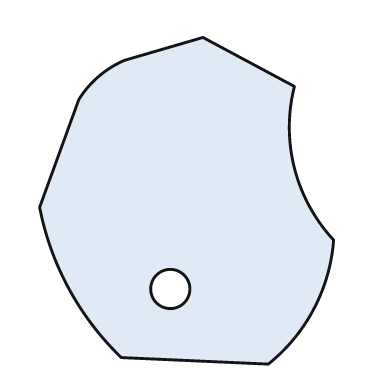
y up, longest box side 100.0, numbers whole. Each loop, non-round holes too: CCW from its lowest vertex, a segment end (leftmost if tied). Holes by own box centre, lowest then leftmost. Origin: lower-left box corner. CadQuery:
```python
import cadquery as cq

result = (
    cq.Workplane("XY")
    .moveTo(70.0, 0.0)
    .threePointArc((84.0, 17.0), (90.0, 38.0))
    .threePointArc((78.0, 60.0), (78.0, 85.0))
    .lineTo(50.0, 100.0)
    .lineTo(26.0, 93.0)
    .threePointArc((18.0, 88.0), (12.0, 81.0))
    .lineTo(0.0, 48.0)
    .threePointArc((9.0, 23.0), (25.0, 2.0))
    .close()
    .moveTo(40.0, 23.0)
    .circle(6.0)
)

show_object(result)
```